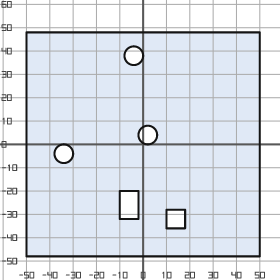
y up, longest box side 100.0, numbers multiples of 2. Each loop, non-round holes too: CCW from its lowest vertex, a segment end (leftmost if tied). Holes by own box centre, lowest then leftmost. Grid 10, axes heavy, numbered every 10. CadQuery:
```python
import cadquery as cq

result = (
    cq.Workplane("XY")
    .moveTo(-50.0, -48.0)
    .lineTo(50.0, -48.0)
    .lineTo(50.0, 48.0)
    .lineTo(-50.0, 48.0)
    .close()
    .moveTo(10.0, -36.0)
    .lineTo(18.0, -36.0)
    .lineTo(18.0, -28.0)
    .lineTo(10.0, -28.0)
    .close()
    .moveTo(-10.0, -32.0)
    .lineTo(-2.0, -32.0)
    .lineTo(-2.0, -20.0)
    .lineTo(-10.0, -20.0)
    .close()
    .moveTo(-34.0, -4.0)
    .circle(4.0)
    .moveTo(2.0, 4.0)
    .circle(4.0)
    .moveTo(-4.0, 38.0)
    .circle(4.0)
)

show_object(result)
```